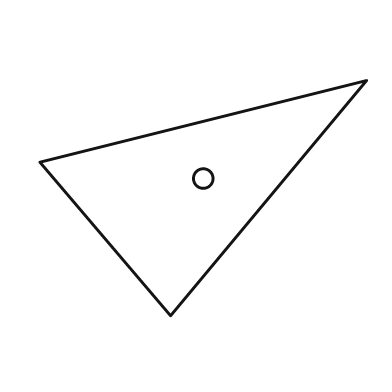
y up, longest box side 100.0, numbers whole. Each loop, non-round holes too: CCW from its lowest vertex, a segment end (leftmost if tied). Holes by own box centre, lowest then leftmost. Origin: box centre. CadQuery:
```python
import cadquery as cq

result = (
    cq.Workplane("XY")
    .moveTo(-10.0, -36.0)
    .lineTo(50.0, 36.0)
    .lineTo(-50.0, 11.0)
    .close()
    .moveTo(0.0, 6.0)
    .circle(3.0)
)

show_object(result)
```